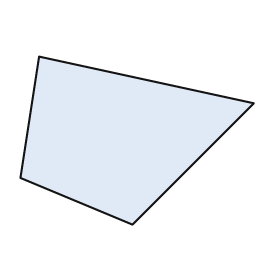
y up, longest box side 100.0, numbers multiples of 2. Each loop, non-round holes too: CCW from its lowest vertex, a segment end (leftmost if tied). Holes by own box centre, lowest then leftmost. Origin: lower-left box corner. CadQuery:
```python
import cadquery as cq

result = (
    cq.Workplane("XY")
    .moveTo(48.0, 0.0)
    .lineTo(100.0, 52.0)
    .lineTo(8.0, 72.0)
    .lineTo(0.0, 20.0)
    .close()
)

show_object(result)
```